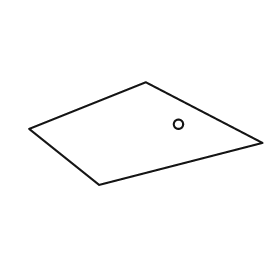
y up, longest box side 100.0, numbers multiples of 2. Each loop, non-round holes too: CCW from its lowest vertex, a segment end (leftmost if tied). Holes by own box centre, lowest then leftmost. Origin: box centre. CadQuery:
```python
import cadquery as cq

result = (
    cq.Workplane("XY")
    .moveTo(-20.0, -22.0)
    .lineTo(50.0, -4.0)
    .lineTo(0.0, 22.0)
    .lineTo(-50.0, 2.0)
    .close()
    .moveTo(14.0, 4.0)
    .circle(2.0)
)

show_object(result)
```